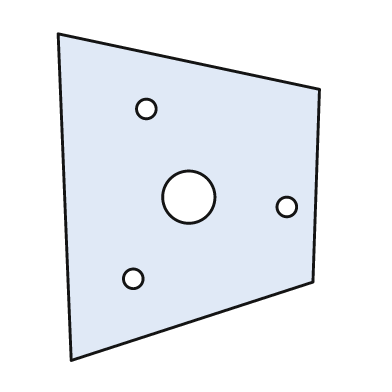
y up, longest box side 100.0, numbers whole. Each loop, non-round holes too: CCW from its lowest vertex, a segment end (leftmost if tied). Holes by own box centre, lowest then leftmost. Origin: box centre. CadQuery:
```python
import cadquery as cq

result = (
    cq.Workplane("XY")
    .moveTo(-36.0, -50.0)
    .lineTo(38.0, -26.0)
    .lineTo(40.0, 33.0)
    .lineTo(-40.0, 50.0)
    .close()
    .moveTo(-17.0, -25.0)
    .circle(3.0)
    .moveTo(30.0, -3.0)
    .circle(3.0)
    .moveTo(0.0, 0.0)
    .circle(8.0)
    .moveTo(-13.0, 27.0)
    .circle(3.0)
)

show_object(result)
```